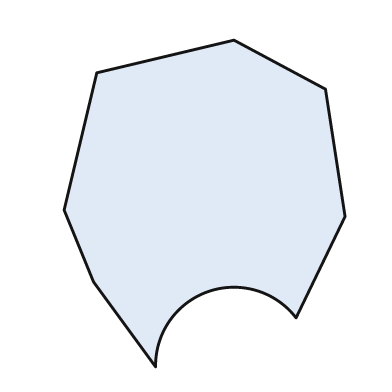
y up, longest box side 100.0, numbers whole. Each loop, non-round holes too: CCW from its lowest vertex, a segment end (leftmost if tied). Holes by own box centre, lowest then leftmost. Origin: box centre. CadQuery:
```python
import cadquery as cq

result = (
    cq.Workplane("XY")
    .moveTo(-15.0, -50.0)
    .threePointArc((1.0, -27.0), (28.0, -35.0))
    .lineTo(43.0, -4.0)
    .lineTo(37.0, 35.0)
    .lineTo(9.0, 50.0)
    .lineTo(-33.0, 40.0)
    .lineTo(-43.0, -2.0)
    .lineTo(-34.0, -24.0)
    .close()
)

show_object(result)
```